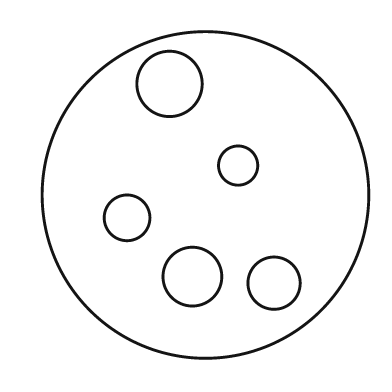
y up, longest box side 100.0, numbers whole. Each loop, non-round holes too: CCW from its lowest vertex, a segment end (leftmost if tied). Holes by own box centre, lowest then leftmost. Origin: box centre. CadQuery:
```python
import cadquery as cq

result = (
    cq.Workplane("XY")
    .moveTo(0.0, 0.0)
    .circle(50.0)
    .moveTo(21.0, -27.0)
    .circle(8.0)
    .moveTo(-4.0, -25.0)
    .circle(9.0)
    .moveTo(-24.0, -7.0)
    .circle(7.0)
    .moveTo(10.0, 9.0)
    .circle(6.0)
    .moveTo(-11.0, 34.0)
    .circle(10.0)
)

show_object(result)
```